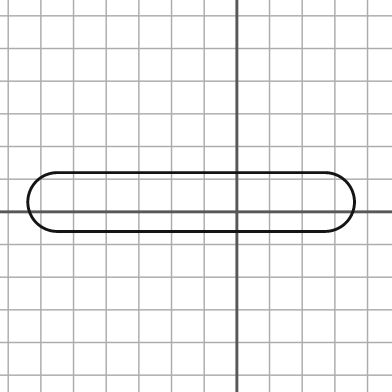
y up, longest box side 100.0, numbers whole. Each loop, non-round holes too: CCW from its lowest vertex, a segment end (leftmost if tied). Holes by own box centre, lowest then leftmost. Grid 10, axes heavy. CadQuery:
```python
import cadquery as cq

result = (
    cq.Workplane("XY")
    .moveTo(-55.0, -6.0)
    .lineTo(27.0, -6.0)
    .threePointArc((36.0, 3.0), (27.0, 12.0))
    .lineTo(-55.0, 12.0)
    .threePointArc((-64.0, 3.0), (-55.0, -6.0))
    .close()
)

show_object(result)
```